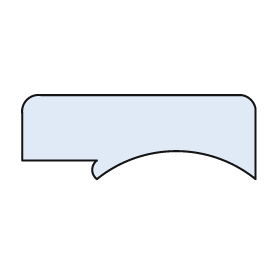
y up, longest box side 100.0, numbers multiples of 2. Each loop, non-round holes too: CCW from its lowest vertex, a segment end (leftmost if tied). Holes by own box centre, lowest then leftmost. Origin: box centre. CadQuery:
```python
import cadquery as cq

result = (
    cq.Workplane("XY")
    .moveTo(-18.0, -18.0)
    .threePointArc((16.0, -6.0), (50.0, -18.0))
    .lineTo(50.0, 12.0)
    .threePointArc((48.0, 16.0), (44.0, 18.0))
    .lineTo(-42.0, 18.0)
    .threePointArc((-48.0, 16.0), (-50.0, 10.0))
    .lineTo(-50.0, -10.0)
    .lineTo(-18.0, -10.0)
    .threePointArc((-20.0, -14.0), (-18.0, -18.0))
    .close()
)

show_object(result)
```